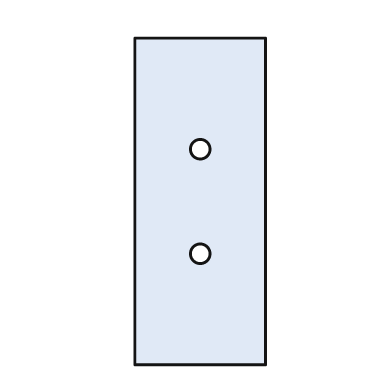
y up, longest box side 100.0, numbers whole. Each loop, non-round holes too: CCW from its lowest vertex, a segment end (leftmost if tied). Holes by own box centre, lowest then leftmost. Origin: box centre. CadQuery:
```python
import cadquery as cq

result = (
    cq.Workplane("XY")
    .moveTo(-20.0, -50.0)
    .lineTo(20.0, -50.0)
    .lineTo(20.0, 50.0)
    .lineTo(-20.0, 50.0)
    .close()
    .moveTo(0.0, -16.0)
    .circle(3.0)
    .moveTo(0.0, 16.0)
    .circle(3.0)
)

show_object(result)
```